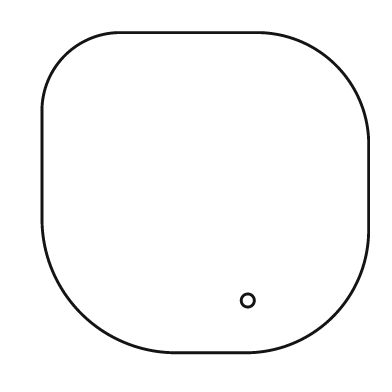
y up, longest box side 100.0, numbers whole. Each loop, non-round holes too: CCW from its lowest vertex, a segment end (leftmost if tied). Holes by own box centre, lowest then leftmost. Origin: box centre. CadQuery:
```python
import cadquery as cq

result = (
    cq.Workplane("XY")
    .moveTo(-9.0, -49.0)
    .lineTo(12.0, -49.0)
    .threePointArc((39.0, -38.0), (50.0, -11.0))
    .lineTo(50.0, 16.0)
    .threePointArc((40.0, 39.0), (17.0, 49.0))
    .lineTo(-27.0, 49.0)
    .threePointArc((-43.0, 42.0), (-50.0, 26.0))
    .lineTo(-50.0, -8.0)
    .threePointArc((-38.0, -37.0), (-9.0, -49.0))
    .close()
    .moveTo(13.0, -33.0)
    .circle(2.0)
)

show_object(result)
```